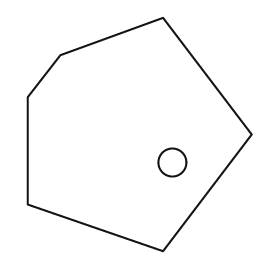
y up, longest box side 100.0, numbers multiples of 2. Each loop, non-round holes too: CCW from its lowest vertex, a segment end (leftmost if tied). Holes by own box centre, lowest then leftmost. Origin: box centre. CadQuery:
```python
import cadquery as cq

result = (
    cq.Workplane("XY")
    .moveTo(10.0, -50.0)
    .lineTo(48.0, 0.0)
    .lineTo(10.0, 50.0)
    .lineTo(-34.0, 34.0)
    .lineTo(-48.0, 16.0)
    .lineTo(-48.0, -30.0)
    .close()
    .moveTo(14.0, -12.0)
    .circle(6.0)
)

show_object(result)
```